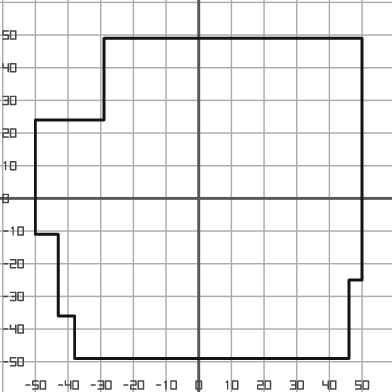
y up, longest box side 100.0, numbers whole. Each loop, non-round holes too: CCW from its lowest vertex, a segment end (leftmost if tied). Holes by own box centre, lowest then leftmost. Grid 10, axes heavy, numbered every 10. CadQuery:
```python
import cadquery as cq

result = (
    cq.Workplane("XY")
    .moveTo(-38.0, -49.0)
    .lineTo(46.0, -49.0)
    .lineTo(46.0, -25.0)
    .lineTo(50.0, -25.0)
    .lineTo(50.0, 49.0)
    .lineTo(-29.0, 49.0)
    .lineTo(-29.0, 24.0)
    .lineTo(-50.0, 24.0)
    .lineTo(-50.0, -11.0)
    .lineTo(-43.0, -11.0)
    .lineTo(-43.0, -36.0)
    .lineTo(-38.0, -36.0)
    .close()
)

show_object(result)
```